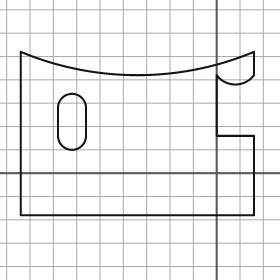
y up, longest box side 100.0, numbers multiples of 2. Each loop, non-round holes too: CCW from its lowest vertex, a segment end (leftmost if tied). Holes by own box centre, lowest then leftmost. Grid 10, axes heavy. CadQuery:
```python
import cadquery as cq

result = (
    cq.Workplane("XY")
    .moveTo(-84.0, -18.0)
    .lineTo(16.0, -18.0)
    .lineTo(16.0, 16.0)
    .lineTo(0.0, 16.0)
    .lineTo(0.0, 42.0)
    .threePointArc((8.0, 38.0), (16.0, 42.0))
    .lineTo(16.0, 52.0)
    .threePointArc((-34.0, 42.0), (-84.0, 52.0))
    .close()
    .moveTo(-68.0, 16.0)
    .threePointArc((-62.0, 10.0), (-56.0, 16.0))
    .lineTo(-56.0, 28.0)
    .threePointArc((-62.0, 34.0), (-68.0, 28.0))
    .close()
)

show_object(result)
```